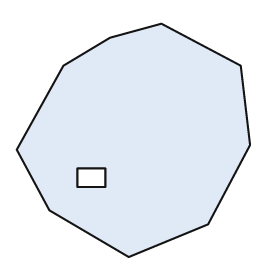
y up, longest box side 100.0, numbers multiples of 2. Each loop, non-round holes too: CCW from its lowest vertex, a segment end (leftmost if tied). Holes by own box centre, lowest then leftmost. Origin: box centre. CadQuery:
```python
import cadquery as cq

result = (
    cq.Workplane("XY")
    .moveTo(-2.0, -50.0)
    .lineTo(32.0, -36.0)
    .lineTo(50.0, -2.0)
    .lineTo(46.0, 32.0)
    .lineTo(12.0, 50.0)
    .lineTo(-10.0, 44.0)
    .lineTo(-30.0, 32.0)
    .lineTo(-50.0, -4.0)
    .lineTo(-36.0, -30.0)
    .close()
    .moveTo(-24.0, -20.0)
    .lineTo(-12.0, -20.0)
    .lineTo(-12.0, -12.0)
    .lineTo(-24.0, -12.0)
    .close()
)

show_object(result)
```